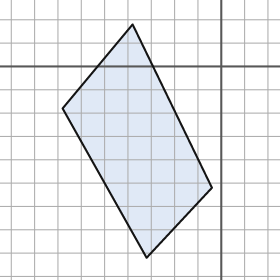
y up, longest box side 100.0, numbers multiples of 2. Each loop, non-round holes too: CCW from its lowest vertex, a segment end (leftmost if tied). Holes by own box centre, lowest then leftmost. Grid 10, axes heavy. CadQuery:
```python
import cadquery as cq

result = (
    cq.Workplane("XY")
    .moveTo(-32.0, -82.0)
    .lineTo(-4.0, -52.0)
    .lineTo(-38.0, 18.0)
    .lineTo(-68.0, -18.0)
    .close()
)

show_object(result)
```